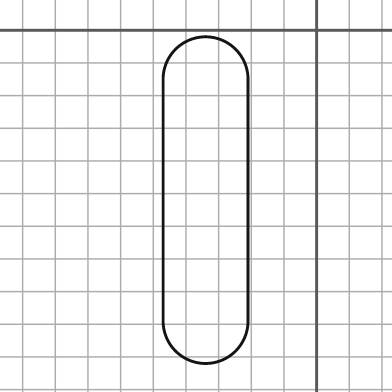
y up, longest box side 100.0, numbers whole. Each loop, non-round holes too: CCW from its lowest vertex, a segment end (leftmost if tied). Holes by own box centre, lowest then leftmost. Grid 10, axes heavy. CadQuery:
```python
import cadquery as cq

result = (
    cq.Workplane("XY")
    .moveTo(-47.0, -89.0)
    .threePointArc((-34.0, -102.0), (-21.0, -89.0))
    .lineTo(-21.0, -15.0)
    .threePointArc((-34.0, -2.0), (-47.0, -15.0))
    .close()
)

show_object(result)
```